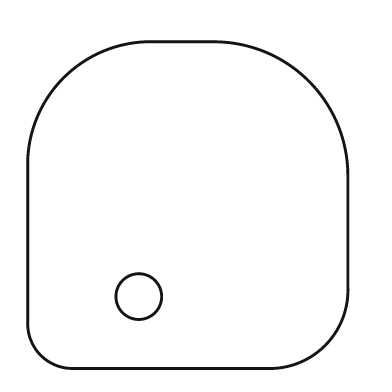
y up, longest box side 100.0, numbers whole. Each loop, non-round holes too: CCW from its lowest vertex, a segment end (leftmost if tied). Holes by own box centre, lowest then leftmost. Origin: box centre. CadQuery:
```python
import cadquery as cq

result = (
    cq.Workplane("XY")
    .moveTo(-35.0, -50.0)
    .lineTo(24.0, -50.0)
    .threePointArc((42.0, -43.0), (49.0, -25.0))
    .lineTo(49.0, 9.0)
    .threePointArc((37.0, 38.0), (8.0, 50.0))
    .lineTo(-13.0, 50.0)
    .threePointArc((-38.0, 39.0), (-49.0, 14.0))
    .lineTo(-49.0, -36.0)
    .threePointArc((-45.0, -46.0), (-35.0, -50.0))
    .close()
    .moveTo(-15.0, -28.0)
    .circle(7.0)
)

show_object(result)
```